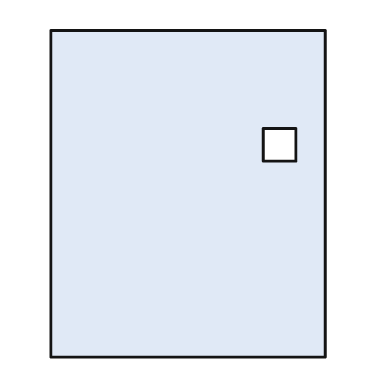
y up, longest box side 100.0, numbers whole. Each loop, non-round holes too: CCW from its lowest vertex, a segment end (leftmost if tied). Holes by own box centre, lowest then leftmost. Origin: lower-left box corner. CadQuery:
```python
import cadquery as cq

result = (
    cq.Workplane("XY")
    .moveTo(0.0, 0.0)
    .lineTo(84.0, 0.0)
    .lineTo(84.0, 100.0)
    .lineTo(0.0, 100.0)
    .close()
    .moveTo(65.0, 60.0)
    .lineTo(75.0, 60.0)
    .lineTo(75.0, 70.0)
    .lineTo(65.0, 70.0)
    .close()
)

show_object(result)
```